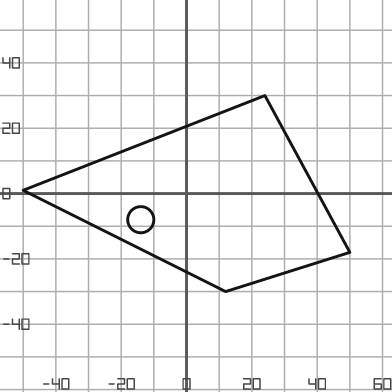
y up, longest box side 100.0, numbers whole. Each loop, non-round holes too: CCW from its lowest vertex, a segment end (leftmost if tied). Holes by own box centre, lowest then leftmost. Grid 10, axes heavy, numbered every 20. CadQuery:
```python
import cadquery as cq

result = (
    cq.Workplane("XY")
    .moveTo(12.0, -30.0)
    .lineTo(50.0, -18.0)
    .lineTo(24.0, 30.0)
    .lineTo(-50.0, 1.0)
    .close()
    .moveTo(-14.0, -8.0)
    .circle(4.0)
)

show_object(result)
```